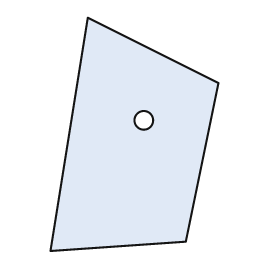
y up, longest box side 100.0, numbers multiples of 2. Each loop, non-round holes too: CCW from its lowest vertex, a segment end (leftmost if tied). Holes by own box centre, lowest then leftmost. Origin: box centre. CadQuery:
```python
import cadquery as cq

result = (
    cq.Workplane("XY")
    .moveTo(-36.0, -50.0)
    .lineTo(22.0, -46.0)
    .lineTo(36.0, 22.0)
    .lineTo(-20.0, 50.0)
    .close()
    .moveTo(4.0, 6.0)
    .circle(4.0)
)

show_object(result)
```